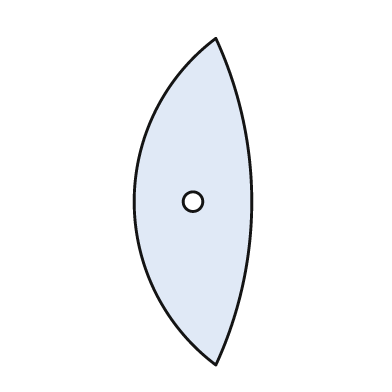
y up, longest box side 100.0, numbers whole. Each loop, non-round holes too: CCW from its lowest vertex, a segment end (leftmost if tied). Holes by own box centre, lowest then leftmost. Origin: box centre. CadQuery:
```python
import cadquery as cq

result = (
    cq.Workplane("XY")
    .moveTo(7.0, -50.0)
    .threePointArc((18.0, 0.0), (7.0, 50.0))
    .threePointArc((-18.0, 0.0), (7.0, -50.0))
    .close()
    .moveTo(0.0, 0.0)
    .circle(3.0)
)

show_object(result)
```